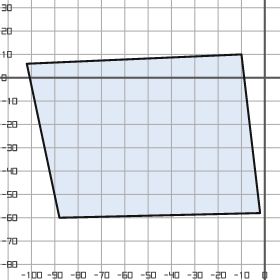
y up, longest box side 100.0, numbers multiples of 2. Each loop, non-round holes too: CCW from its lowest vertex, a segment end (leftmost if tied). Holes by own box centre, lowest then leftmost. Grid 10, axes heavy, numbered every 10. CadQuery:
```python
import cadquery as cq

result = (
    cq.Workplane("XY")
    .moveTo(-88.0, -60.0)
    .lineTo(-2.0, -58.0)
    .lineTo(-10.0, 10.0)
    .lineTo(-102.0, 6.0)
    .close()
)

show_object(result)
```